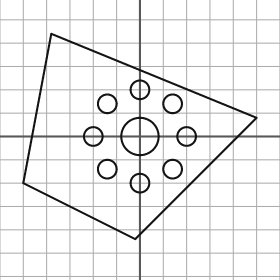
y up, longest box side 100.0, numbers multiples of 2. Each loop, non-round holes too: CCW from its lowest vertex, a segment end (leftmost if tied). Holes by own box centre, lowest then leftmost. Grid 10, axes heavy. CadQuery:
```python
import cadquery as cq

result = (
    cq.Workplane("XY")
    .moveTo(-2.0, -44.0)
    .lineTo(50.0, 8.0)
    .lineTo(-38.0, 44.0)
    .lineTo(-50.0, -20.0)
    .close()
    .moveTo(0.0, -20.0)
    .circle(4.0)
    .moveTo(-14.0, -14.0)
    .circle(4.0)
    .moveTo(14.0, -14.0)
    .circle(4.0)
    .moveTo(-20.0, 0.0)
    .circle(4.0)
    .moveTo(0.0, 0.0)
    .circle(8.0)
    .moveTo(20.0, 0.0)
    .circle(4.0)
    .moveTo(-14.0, 14.0)
    .circle(4.0)
    .moveTo(14.0, 14.0)
    .circle(4.0)
    .moveTo(0.0, 20.0)
    .circle(4.0)
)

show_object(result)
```